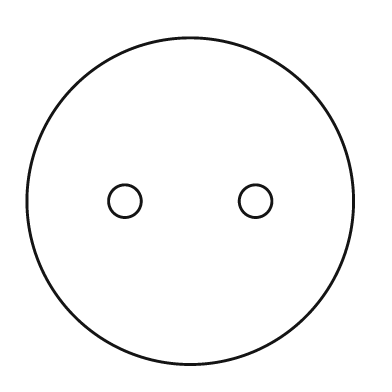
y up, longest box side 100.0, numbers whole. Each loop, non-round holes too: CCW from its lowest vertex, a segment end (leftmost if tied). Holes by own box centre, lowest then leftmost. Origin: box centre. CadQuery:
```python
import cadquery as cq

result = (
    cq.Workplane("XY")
    .moveTo(0.0, 0.0)
    .circle(50.0)
    .moveTo(-20.0, 0.0)
    .circle(5.0)
    .moveTo(20.0, 0.0)
    .circle(5.0)
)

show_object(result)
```